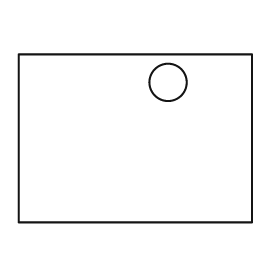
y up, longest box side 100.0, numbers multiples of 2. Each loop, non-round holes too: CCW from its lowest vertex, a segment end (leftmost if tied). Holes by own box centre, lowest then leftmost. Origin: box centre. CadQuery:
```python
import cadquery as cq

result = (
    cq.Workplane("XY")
    .moveTo(-50.0, -36.0)
    .lineTo(50.0, -36.0)
    .lineTo(50.0, 36.0)
    .lineTo(-50.0, 36.0)
    .close()
    .moveTo(14.0, 24.0)
    .circle(8.0)
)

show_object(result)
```